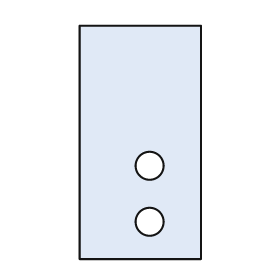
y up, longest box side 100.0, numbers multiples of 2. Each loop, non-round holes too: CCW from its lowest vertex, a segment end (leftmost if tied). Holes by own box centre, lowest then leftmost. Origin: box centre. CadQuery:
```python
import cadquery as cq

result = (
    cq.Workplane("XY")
    .moveTo(-26.0, -50.0)
    .lineTo(26.0, -50.0)
    .lineTo(26.0, 50.0)
    .lineTo(-26.0, 50.0)
    .close()
    .moveTo(4.0, -34.0)
    .circle(6.0)
    .moveTo(4.0, -10.0)
    .circle(6.0)
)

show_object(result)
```